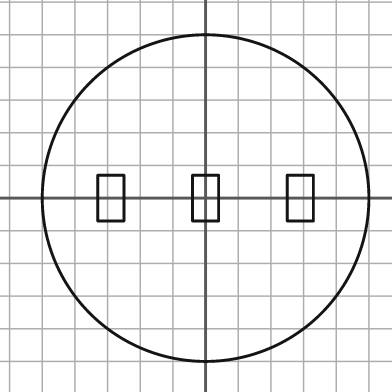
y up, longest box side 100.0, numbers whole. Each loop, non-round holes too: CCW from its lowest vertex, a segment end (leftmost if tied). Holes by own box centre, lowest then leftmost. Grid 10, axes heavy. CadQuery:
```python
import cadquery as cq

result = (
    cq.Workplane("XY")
    .moveTo(0.0, 0.0)
    .circle(50.0)
    .moveTo(-33.0, -7.0)
    .lineTo(-25.0, -7.0)
    .lineTo(-25.0, 7.0)
    .lineTo(-33.0, 7.0)
    .close()
    .moveTo(-4.0, -7.0)
    .lineTo(4.0, -7.0)
    .lineTo(4.0, 7.0)
    .lineTo(-4.0, 7.0)
    .close()
    .moveTo(25.0, -7.0)
    .lineTo(33.0, -7.0)
    .lineTo(33.0, 7.0)
    .lineTo(25.0, 7.0)
    .close()
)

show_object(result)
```